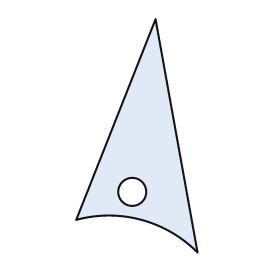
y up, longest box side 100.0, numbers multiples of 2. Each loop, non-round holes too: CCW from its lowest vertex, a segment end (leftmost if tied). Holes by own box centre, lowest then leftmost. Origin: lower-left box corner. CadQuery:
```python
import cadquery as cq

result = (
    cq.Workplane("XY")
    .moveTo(52.0, 0.0)
    .lineTo(34.0, 100.0)
    .lineTo(0.0, 14.0)
    .threePointArc((28.0, 14.0), (52.0, 0.0))
    .close()
    .moveTo(24.0, 26.0)
    .circle(6.0)
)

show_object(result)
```